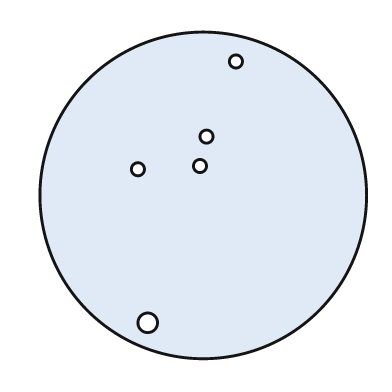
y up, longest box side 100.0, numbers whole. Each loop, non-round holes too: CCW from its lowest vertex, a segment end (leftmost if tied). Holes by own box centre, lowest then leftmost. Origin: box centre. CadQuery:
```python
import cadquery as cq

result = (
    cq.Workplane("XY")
    .moveTo(0.0, 0.0)
    .circle(50.0)
    .moveTo(-17.0, -39.0)
    .circle(3.0)
    .moveTo(-20.0, 8.0)
    .circle(2.0)
    .moveTo(-1.0, 9.0)
    .circle(2.0)
    .moveTo(1.0, 18.0)
    .circle(2.0)
    .moveTo(10.0, 41.0)
    .circle(2.0)
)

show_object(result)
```